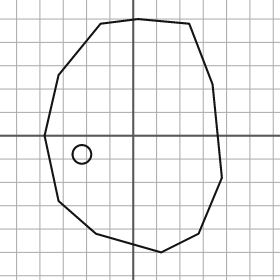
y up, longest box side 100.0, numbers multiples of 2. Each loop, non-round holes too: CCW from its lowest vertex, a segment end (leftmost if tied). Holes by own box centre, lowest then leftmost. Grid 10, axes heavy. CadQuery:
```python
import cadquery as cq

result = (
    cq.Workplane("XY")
    .moveTo(12.0, -50.0)
    .lineTo(28.0, -42.0)
    .lineTo(38.0, -18.0)
    .lineTo(34.0, 22.0)
    .lineTo(24.0, 48.0)
    .lineTo(2.0, 50.0)
    .lineTo(-14.0, 48.0)
    .lineTo(-32.0, 26.0)
    .lineTo(-38.0, 0.0)
    .lineTo(-32.0, -28.0)
    .lineTo(-16.0, -42.0)
    .close()
    .moveTo(-22.0, -8.0)
    .circle(4.0)
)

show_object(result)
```